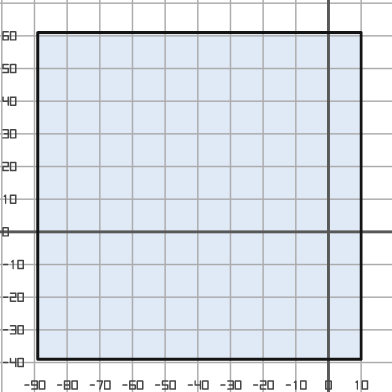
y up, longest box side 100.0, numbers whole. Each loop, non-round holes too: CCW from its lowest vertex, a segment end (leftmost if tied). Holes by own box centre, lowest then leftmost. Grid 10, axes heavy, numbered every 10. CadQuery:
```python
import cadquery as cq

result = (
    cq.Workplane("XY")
    .moveTo(-89.0, -39.0)
    .lineTo(10.0, -39.0)
    .lineTo(10.0, 61.0)
    .lineTo(-89.0, 61.0)
    .close()
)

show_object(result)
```